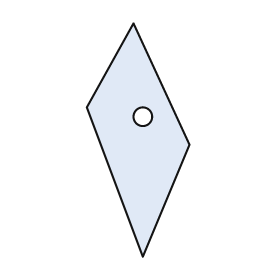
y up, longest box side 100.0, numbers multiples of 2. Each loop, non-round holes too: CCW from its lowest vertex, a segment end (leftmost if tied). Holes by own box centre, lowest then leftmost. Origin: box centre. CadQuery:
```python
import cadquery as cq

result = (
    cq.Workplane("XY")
    .moveTo(2.0, -50.0)
    .lineTo(22.0, -2.0)
    .lineTo(-2.0, 50.0)
    .lineTo(-22.0, 14.0)
    .close()
    .moveTo(2.0, 10.0)
    .circle(4.0)
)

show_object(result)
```